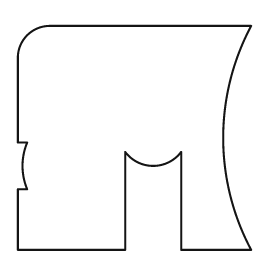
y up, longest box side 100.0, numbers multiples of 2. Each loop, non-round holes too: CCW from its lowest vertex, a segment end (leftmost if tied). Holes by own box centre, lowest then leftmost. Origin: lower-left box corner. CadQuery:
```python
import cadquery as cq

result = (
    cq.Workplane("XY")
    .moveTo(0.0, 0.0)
    .lineTo(46.0, 0.0)
    .lineTo(46.0, 42.0)
    .threePointArc((58.0, 36.0), (70.0, 42.0))
    .lineTo(70.0, 0.0)
    .lineTo(100.0, 0.0)
    .threePointArc((88.0, 48.0), (100.0, 96.0))
    .lineTo(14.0, 96.0)
    .threePointArc((4.0, 92.0), (0.0, 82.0))
    .lineTo(0.0, 46.0)
    .lineTo(4.0, 46.0)
    .threePointArc((2.0, 36.0), (4.0, 26.0))
    .lineTo(0.0, 26.0)
    .close()
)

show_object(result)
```